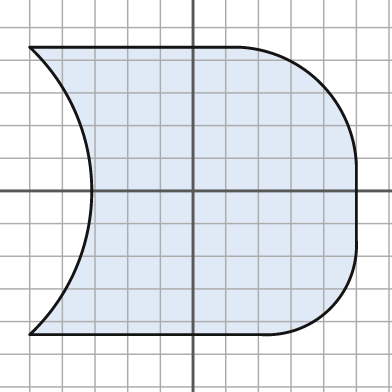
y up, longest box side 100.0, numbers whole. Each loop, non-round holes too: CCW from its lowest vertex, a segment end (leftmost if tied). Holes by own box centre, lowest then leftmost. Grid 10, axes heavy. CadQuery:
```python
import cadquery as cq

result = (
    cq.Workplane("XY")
    .moveTo(-50.0, -44.0)
    .lineTo(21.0, -44.0)
    .threePointArc((42.0, -36.0), (50.0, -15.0))
    .lineTo(50.0, 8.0)
    .threePointArc((39.0, 33.0), (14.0, 44.0))
    .lineTo(-50.0, 44.0)
    .threePointArc((-31.0, 0.0), (-50.0, -44.0))
    .close()
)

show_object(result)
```